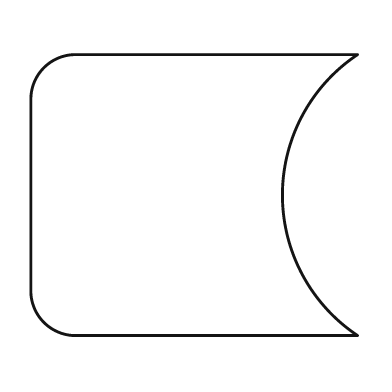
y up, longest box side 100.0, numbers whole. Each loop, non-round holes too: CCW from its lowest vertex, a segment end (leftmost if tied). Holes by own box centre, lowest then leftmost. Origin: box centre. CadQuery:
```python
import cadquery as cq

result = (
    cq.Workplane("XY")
    .moveTo(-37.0, -43.0)
    .lineTo(50.0, -43.0)
    .threePointArc((27.0, 0.0), (50.0, 43.0))
    .lineTo(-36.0, 43.0)
    .threePointArc((-46.0, 39.0), (-50.0, 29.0))
    .lineTo(-50.0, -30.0)
    .threePointArc((-46.0, -39.0), (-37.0, -43.0))
    .close()
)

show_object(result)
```